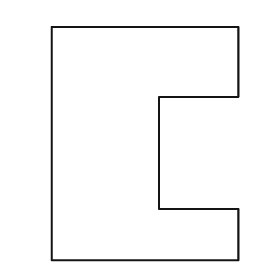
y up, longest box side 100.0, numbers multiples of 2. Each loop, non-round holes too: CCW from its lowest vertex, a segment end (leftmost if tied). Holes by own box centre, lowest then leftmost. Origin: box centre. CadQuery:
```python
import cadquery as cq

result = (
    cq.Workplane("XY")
    .moveTo(-40.0, -50.0)
    .lineTo(40.0, -50.0)
    .lineTo(40.0, -28.0)
    .lineTo(6.0, -28.0)
    .lineTo(6.0, 20.0)
    .lineTo(40.0, 20.0)
    .lineTo(40.0, 50.0)
    .lineTo(-40.0, 50.0)
    .close()
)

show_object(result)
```